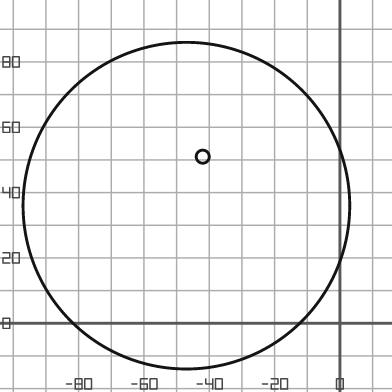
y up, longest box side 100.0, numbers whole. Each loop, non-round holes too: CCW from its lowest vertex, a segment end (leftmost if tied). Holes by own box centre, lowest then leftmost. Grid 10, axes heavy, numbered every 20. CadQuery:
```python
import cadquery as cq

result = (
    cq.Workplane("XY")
    .moveTo(-47.0, 36.0)
    .circle(50.0)
    .moveTo(-42.0, 51.0)
    .circle(2.0)
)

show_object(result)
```